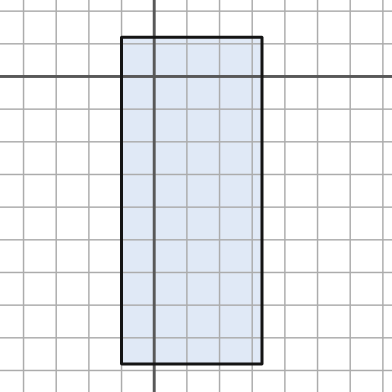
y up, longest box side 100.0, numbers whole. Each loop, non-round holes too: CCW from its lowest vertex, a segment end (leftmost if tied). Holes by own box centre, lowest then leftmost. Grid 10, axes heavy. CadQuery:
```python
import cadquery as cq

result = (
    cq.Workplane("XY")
    .moveTo(-10.0, -88.0)
    .lineTo(33.0, -88.0)
    .lineTo(33.0, 12.0)
    .lineTo(-10.0, 12.0)
    .close()
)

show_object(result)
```